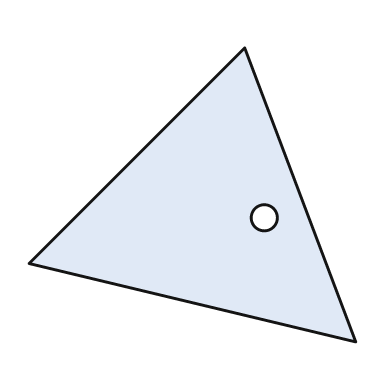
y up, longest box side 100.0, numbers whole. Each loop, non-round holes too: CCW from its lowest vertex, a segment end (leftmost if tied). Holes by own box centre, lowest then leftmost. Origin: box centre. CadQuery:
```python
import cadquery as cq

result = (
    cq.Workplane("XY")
    .moveTo(50.0, -45.0)
    .lineTo(16.0, 45.0)
    .lineTo(-50.0, -21.0)
    .close()
    .moveTo(22.0, -7.0)
    .circle(4.0)
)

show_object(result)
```